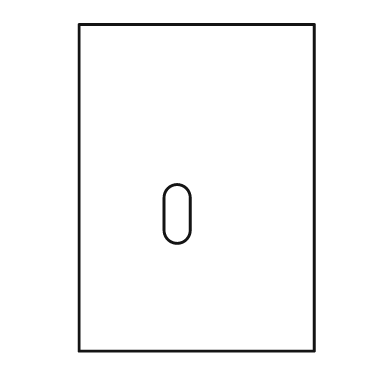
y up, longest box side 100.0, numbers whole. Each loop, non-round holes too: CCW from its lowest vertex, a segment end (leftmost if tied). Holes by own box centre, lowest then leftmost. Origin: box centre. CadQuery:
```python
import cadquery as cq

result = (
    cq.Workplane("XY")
    .moveTo(-36.0, -50.0)
    .lineTo(36.0, -50.0)
    .lineTo(36.0, 50.0)
    .lineTo(-36.0, 50.0)
    .close()
    .moveTo(-10.0, -13.0)
    .threePointArc((-6.0, -17.0), (-2.0, -13.0))
    .lineTo(-2.0, -3.0)
    .threePointArc((-6.0, 1.0), (-10.0, -3.0))
    .close()
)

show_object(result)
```